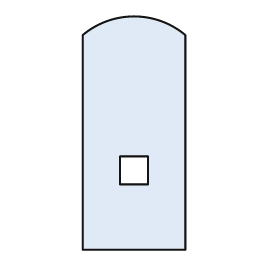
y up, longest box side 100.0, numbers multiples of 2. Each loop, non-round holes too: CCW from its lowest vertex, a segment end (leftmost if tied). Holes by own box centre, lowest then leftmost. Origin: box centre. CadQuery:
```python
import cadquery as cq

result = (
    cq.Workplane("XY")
    .moveTo(-22.0, -50.0)
    .lineTo(22.0, -50.0)
    .lineTo(22.0, 42.0)
    .threePointArc((0.0, 50.0), (-22.0, 42.0))
    .close()
    .moveTo(-6.0, -22.0)
    .lineTo(6.0, -22.0)
    .lineTo(6.0, -10.0)
    .lineTo(-6.0, -10.0)
    .close()
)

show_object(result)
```